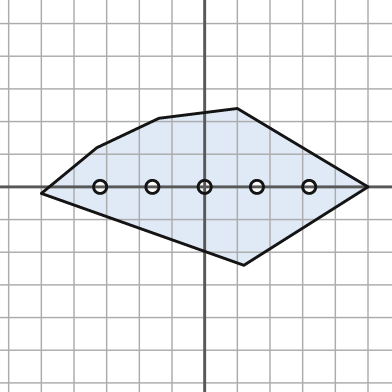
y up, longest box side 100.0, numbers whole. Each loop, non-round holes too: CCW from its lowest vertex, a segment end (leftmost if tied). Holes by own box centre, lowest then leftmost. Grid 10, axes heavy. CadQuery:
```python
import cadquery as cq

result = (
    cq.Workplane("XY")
    .moveTo(12.0, -24.0)
    .lineTo(50.0, 0.0)
    .lineTo(10.0, 24.0)
    .lineTo(-14.0, 21.0)
    .lineTo(-33.0, 12.0)
    .lineTo(-50.0, -2.0)
    .close()
    .moveTo(-32.0, 0.0)
    .circle(2.0)
    .moveTo(-16.0, 0.0)
    .circle(2.0)
    .moveTo(0.0, 0.0)
    .circle(2.0)
    .moveTo(16.0, 0.0)
    .circle(2.0)
    .moveTo(32.0, 0.0)
    .circle(2.0)
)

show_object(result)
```